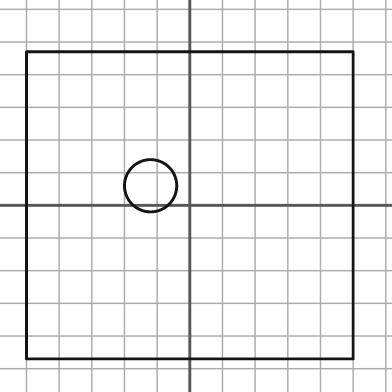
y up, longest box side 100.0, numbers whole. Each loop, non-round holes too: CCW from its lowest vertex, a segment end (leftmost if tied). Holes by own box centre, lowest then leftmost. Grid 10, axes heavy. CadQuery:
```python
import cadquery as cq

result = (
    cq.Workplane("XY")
    .moveTo(-50.0, -47.0)
    .lineTo(50.0, -47.0)
    .lineTo(50.0, 47.0)
    .lineTo(-50.0, 47.0)
    .close()
    .moveTo(-12.0, 6.0)
    .circle(8.0)
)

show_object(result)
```